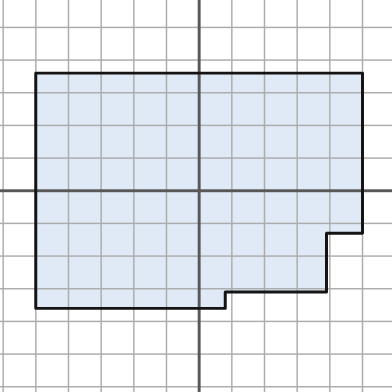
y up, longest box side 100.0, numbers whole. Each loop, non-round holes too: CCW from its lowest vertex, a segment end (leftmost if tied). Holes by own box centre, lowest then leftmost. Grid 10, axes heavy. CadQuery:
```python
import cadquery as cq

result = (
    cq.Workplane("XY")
    .moveTo(-50.0, -36.0)
    .lineTo(8.0, -36.0)
    .lineTo(8.0, -31.0)
    .lineTo(39.0, -31.0)
    .lineTo(39.0, -13.0)
    .lineTo(50.0, -13.0)
    .lineTo(50.0, 36.0)
    .lineTo(-50.0, 36.0)
    .close()
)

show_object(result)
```